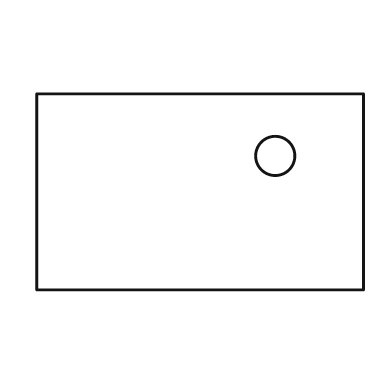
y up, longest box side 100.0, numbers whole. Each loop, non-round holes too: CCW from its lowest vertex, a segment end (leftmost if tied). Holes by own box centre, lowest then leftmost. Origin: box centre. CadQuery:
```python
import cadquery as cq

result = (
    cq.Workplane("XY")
    .moveTo(-50.0, -30.0)
    .lineTo(50.0, -30.0)
    .lineTo(50.0, 30.0)
    .lineTo(-50.0, 30.0)
    .close()
    .moveTo(23.0, 11.0)
    .circle(6.0)
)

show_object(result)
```